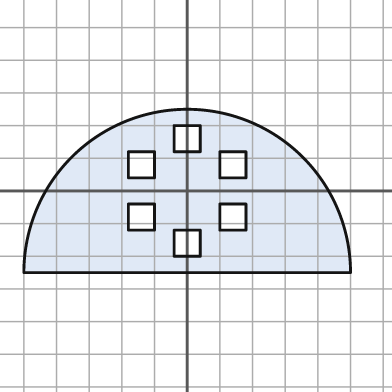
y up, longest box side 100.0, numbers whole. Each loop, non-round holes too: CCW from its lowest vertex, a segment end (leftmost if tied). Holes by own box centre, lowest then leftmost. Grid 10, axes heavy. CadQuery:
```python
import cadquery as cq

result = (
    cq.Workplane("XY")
    .moveTo(-50.0, -25.0)
    .lineTo(50.0, -25.0)
    .threePointArc((0.0, 25.0), (-50.0, -25.0))
    .close()
    .moveTo(-4.0, -20.0)
    .lineTo(4.0, -20.0)
    .lineTo(4.0, -12.0)
    .lineTo(-4.0, -12.0)
    .close()
    .moveTo(-18.0, -12.0)
    .lineTo(-10.0, -12.0)
    .lineTo(-10.0, -4.0)
    .lineTo(-18.0, -4.0)
    .close()
    .moveTo(10.0, -12.0)
    .lineTo(18.0, -12.0)
    .lineTo(18.0, -4.0)
    .lineTo(10.0, -4.0)
    .close()
    .moveTo(-18.0, 4.0)
    .lineTo(-10.0, 4.0)
    .lineTo(-10.0, 12.0)
    .lineTo(-18.0, 12.0)
    .close()
    .moveTo(10.0, 4.0)
    .lineTo(18.0, 4.0)
    .lineTo(18.0, 12.0)
    .lineTo(10.0, 12.0)
    .close()
    .moveTo(-4.0, 12.0)
    .lineTo(4.0, 12.0)
    .lineTo(4.0, 20.0)
    .lineTo(-4.0, 20.0)
    .close()
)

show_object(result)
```